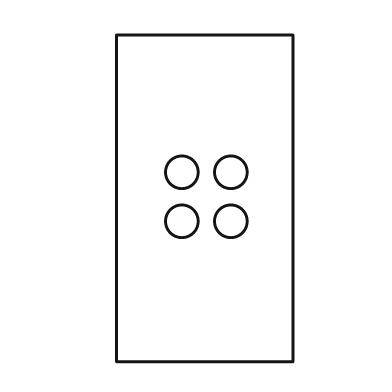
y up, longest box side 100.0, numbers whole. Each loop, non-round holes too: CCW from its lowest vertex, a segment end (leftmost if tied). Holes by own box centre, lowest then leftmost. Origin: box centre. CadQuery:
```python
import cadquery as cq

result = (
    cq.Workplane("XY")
    .moveTo(-27.0, -50.0)
    .lineTo(27.0, -50.0)
    .lineTo(27.0, 50.0)
    .lineTo(-27.0, 50.0)
    .close()
    .moveTo(-7.0, -7.0)
    .circle(5.0)
    .moveTo(8.0, -7.0)
    .circle(5.0)
    .moveTo(-7.0, 8.0)
    .circle(5.0)
    .moveTo(8.0, 8.0)
    .circle(5.0)
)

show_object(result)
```